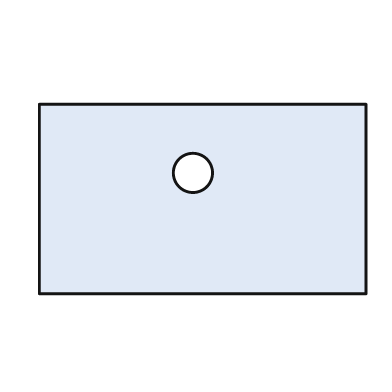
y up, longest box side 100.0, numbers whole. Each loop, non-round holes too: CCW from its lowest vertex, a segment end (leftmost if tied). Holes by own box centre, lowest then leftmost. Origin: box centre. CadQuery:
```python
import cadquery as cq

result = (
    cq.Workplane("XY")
    .moveTo(-50.0, -29.0)
    .lineTo(50.0, -29.0)
    .lineTo(50.0, 29.0)
    .lineTo(-50.0, 29.0)
    .close()
    .moveTo(-3.0, 8.0)
    .circle(6.0)
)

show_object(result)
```